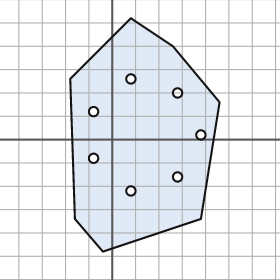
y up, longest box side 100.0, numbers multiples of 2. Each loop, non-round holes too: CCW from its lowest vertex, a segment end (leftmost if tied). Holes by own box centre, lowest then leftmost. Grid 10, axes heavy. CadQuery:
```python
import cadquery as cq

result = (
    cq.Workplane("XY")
    .moveTo(-4.0, -48.0)
    .lineTo(38.0, -34.0)
    .lineTo(46.0, 16.0)
    .lineTo(26.0, 40.0)
    .lineTo(8.0, 52.0)
    .lineTo(-18.0, 26.0)
    .lineTo(-16.0, -34.0)
    .close()
    .moveTo(8.0, -22.0)
    .circle(2.0)
    .moveTo(28.0, -16.0)
    .circle(2.0)
    .moveTo(-8.0, -8.0)
    .circle(2.0)
    .moveTo(38.0, 2.0)
    .circle(2.0)
    .moveTo(-8.0, 12.0)
    .circle(2.0)
    .moveTo(28.0, 20.0)
    .circle(2.0)
    .moveTo(8.0, 26.0)
    .circle(2.0)
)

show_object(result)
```